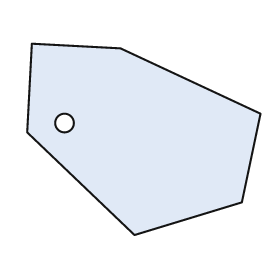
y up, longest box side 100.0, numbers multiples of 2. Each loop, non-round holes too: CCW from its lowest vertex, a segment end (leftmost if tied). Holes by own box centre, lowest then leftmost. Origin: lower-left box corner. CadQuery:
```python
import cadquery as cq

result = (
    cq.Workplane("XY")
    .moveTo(46.0, 0.0)
    .lineTo(92.0, 14.0)
    .lineTo(100.0, 52.0)
    .lineTo(40.0, 80.0)
    .lineTo(2.0, 82.0)
    .lineTo(0.0, 44.0)
    .close()
    .moveTo(16.0, 48.0)
    .circle(4.0)
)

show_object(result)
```